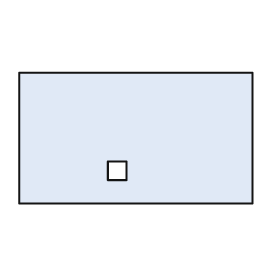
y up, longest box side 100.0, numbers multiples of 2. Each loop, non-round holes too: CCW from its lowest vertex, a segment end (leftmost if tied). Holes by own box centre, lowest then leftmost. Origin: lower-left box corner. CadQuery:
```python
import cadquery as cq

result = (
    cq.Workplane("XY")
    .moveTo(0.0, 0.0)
    .lineTo(100.0, 0.0)
    .lineTo(100.0, 56.0)
    .lineTo(0.0, 56.0)
    .close()
    .moveTo(38.0, 10.0)
    .lineTo(46.0, 10.0)
    .lineTo(46.0, 18.0)
    .lineTo(38.0, 18.0)
    .close()
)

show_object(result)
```